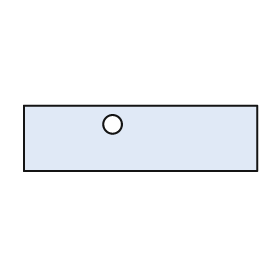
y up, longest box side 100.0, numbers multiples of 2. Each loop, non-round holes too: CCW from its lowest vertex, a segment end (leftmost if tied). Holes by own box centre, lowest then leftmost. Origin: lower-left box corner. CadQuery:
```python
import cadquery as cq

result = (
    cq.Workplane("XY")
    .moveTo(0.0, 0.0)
    .lineTo(100.0, 0.0)
    .lineTo(100.0, 28.0)
    .lineTo(0.0, 28.0)
    .close()
    .moveTo(38.0, 20.0)
    .circle(4.0)
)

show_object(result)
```